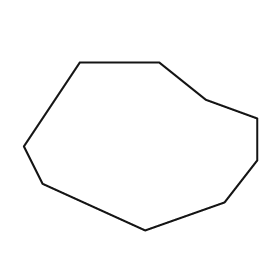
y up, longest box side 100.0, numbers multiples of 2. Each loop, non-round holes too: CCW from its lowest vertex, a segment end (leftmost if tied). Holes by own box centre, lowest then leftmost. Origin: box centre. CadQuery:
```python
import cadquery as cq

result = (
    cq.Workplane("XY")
    .moveTo(2.0, -36.0)
    .lineTo(36.0, -24.0)
    .lineTo(50.0, -6.0)
    .lineTo(50.0, 12.0)
    .lineTo(28.0, 20.0)
    .lineTo(8.0, 36.0)
    .lineTo(-26.0, 36.0)
    .lineTo(-50.0, 0.0)
    .lineTo(-42.0, -16.0)
    .close()
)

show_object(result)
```